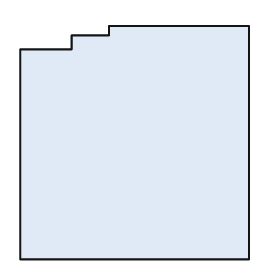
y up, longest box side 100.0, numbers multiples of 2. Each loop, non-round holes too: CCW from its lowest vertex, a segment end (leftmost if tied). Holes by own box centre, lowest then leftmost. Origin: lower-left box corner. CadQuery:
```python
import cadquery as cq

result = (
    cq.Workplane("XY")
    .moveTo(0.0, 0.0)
    .lineTo(98.0, 0.0)
    .lineTo(98.0, 100.0)
    .lineTo(38.0, 100.0)
    .lineTo(38.0, 96.0)
    .lineTo(22.0, 96.0)
    .lineTo(22.0, 90.0)
    .lineTo(0.0, 90.0)
    .close()
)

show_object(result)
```